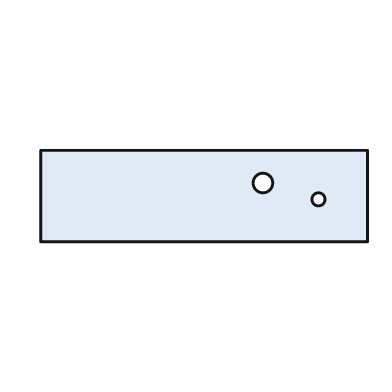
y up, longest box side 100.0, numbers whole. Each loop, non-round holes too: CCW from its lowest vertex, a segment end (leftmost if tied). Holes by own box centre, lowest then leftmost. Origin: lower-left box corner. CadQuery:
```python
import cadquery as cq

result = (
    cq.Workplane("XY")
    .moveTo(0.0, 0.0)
    .lineTo(100.0, 0.0)
    .lineTo(100.0, 28.0)
    .lineTo(0.0, 28.0)
    .close()
    .moveTo(85.0, 13.0)
    .circle(2.0)
    .moveTo(68.0, 18.0)
    .circle(3.0)
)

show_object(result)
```